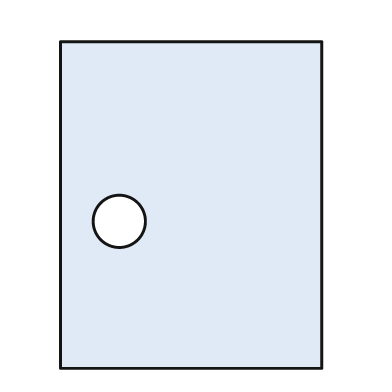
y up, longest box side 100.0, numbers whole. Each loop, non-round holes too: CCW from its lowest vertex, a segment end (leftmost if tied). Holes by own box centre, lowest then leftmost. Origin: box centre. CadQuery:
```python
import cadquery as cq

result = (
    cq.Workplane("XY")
    .moveTo(-40.0, -50.0)
    .lineTo(40.0, -50.0)
    .lineTo(40.0, 50.0)
    .lineTo(-40.0, 50.0)
    .close()
    .moveTo(-22.0, -5.0)
    .circle(8.0)
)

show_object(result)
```